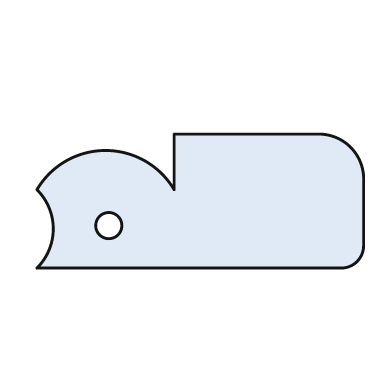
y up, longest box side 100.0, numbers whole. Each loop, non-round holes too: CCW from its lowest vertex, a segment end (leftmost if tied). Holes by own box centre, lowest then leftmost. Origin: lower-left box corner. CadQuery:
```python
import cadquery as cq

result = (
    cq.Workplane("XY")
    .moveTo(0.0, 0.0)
    .lineTo(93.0, 0.0)
    .threePointArc((98.0, 2.0), (100.0, 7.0))
    .lineTo(100.0, 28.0)
    .threePointArc((96.0, 37.0), (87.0, 41.0))
    .lineTo(42.0, 41.0)
    .lineTo(42.0, 24.0)
    .threePointArc((21.0, 36.0), (0.0, 24.0))
    .threePointArc((5.0, 12.0), (0.0, 0.0))
    .close()
    .moveTo(22.0, 13.0)
    .circle(4.0)
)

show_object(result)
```